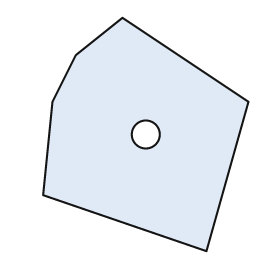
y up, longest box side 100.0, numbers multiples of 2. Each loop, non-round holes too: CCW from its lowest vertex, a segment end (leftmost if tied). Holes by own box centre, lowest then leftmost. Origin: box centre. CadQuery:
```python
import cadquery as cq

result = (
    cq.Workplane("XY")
    .moveTo(26.0, -50.0)
    .lineTo(44.0, 14.0)
    .lineTo(-10.0, 50.0)
    .lineTo(-30.0, 34.0)
    .lineTo(-40.0, 14.0)
    .lineTo(-44.0, -26.0)
    .close()
    .moveTo(0.0, 0.0)
    .circle(6.0)
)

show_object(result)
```